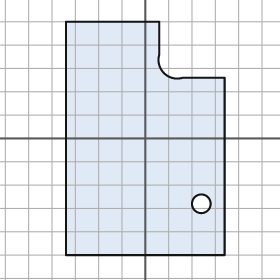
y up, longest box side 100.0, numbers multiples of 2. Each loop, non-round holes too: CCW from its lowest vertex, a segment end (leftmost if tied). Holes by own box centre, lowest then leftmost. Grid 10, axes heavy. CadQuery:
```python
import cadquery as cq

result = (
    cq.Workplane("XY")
    .moveTo(-34.0, -50.0)
    .lineTo(34.0, -50.0)
    .lineTo(34.0, 26.0)
    .lineTo(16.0, 26.0)
    .threePointArc((8.0, 28.0), (6.0, 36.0))
    .lineTo(6.0, 50.0)
    .lineTo(-34.0, 50.0)
    .close()
    .moveTo(24.0, -28.0)
    .circle(4.0)
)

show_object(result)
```